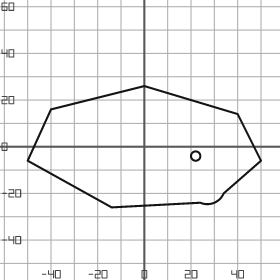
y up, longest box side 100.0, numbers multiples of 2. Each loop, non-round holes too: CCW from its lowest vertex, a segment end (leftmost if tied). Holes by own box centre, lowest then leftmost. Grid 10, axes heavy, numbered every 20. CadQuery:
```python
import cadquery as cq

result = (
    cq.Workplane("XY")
    .moveTo(-14.0, -26.0)
    .lineTo(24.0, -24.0)
    .threePointArc((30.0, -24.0), (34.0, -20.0))
    .lineTo(50.0, -6.0)
    .lineTo(40.0, 14.0)
    .lineTo(0.0, 26.0)
    .lineTo(-40.0, 16.0)
    .lineTo(-50.0, -6.0)
    .close()
    .moveTo(22.0, -4.0)
    .circle(2.0)
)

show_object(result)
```